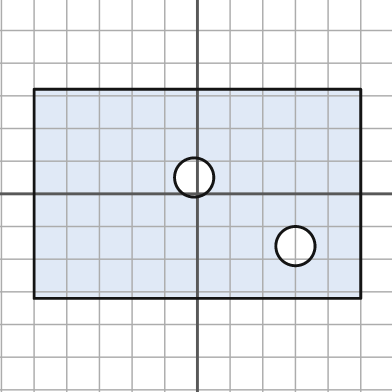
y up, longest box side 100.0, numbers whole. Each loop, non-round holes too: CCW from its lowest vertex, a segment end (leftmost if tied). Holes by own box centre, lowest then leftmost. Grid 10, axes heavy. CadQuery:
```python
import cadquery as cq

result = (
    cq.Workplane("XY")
    .moveTo(-50.0, -32.0)
    .lineTo(50.0, -32.0)
    .lineTo(50.0, 32.0)
    .lineTo(-50.0, 32.0)
    .close()
    .moveTo(30.0, -16.0)
    .circle(6.0)
    .moveTo(-1.0, 5.0)
    .circle(6.0)
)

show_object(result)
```